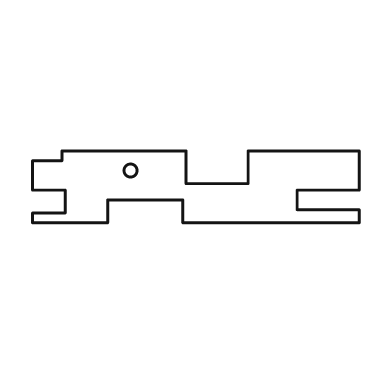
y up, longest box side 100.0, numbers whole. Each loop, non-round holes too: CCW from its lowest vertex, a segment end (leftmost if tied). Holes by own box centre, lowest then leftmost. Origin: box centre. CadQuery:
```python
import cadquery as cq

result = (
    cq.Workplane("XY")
    .moveTo(-50.0, -11.0)
    .lineTo(-27.0, -11.0)
    .lineTo(-27.0, -4.0)
    .lineTo(-4.0, -4.0)
    .lineTo(-4.0, -11.0)
    .lineTo(50.0, -11.0)
    .lineTo(50.0, -7.0)
    .lineTo(31.0, -7.0)
    .lineTo(31.0, -1.0)
    .lineTo(50.0, -1.0)
    .lineTo(50.0, 11.0)
    .lineTo(16.0, 11.0)
    .lineTo(16.0, 1.0)
    .lineTo(-3.0, 1.0)
    .lineTo(-3.0, 11.0)
    .lineTo(-41.0, 11.0)
    .lineTo(-41.0, 8.0)
    .lineTo(-50.0, 8.0)
    .lineTo(-50.0, -1.0)
    .lineTo(-40.0, -1.0)
    .lineTo(-40.0, -8.0)
    .lineTo(-50.0, -8.0)
    .close()
    .moveTo(-20.0, 5.0)
    .circle(2.0)
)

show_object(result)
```